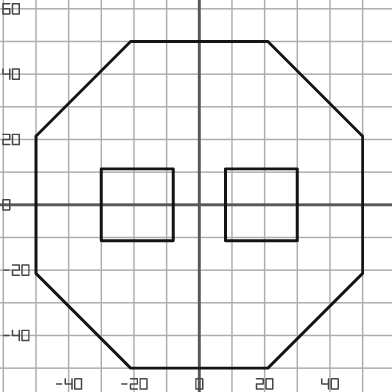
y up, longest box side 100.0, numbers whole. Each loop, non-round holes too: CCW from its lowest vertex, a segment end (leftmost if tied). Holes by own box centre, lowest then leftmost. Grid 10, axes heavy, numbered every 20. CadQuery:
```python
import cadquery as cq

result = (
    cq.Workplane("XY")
    .moveTo(-21.0, -50.0)
    .lineTo(21.0, -50.0)
    .lineTo(50.0, -21.0)
    .lineTo(50.0, 21.0)
    .lineTo(21.0, 50.0)
    .lineTo(-21.0, 50.0)
    .lineTo(-50.0, 21.0)
    .lineTo(-50.0, -21.0)
    .close()
    .moveTo(-30.0, -11.0)
    .lineTo(-8.0, -11.0)
    .lineTo(-8.0, 11.0)
    .lineTo(-30.0, 11.0)
    .close()
    .moveTo(8.0, -11.0)
    .lineTo(30.0, -11.0)
    .lineTo(30.0, 11.0)
    .lineTo(8.0, 11.0)
    .close()
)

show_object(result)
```